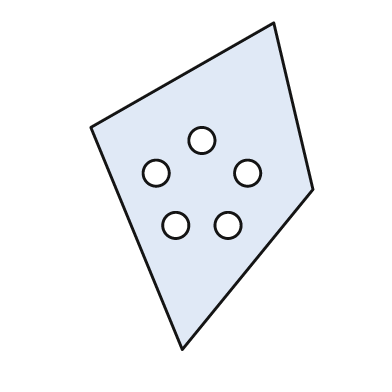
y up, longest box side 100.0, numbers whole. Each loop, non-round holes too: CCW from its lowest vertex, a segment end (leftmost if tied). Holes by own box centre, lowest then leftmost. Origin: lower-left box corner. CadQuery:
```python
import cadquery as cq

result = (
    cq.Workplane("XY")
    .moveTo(28.0, 0.0)
    .lineTo(68.0, 49.0)
    .lineTo(56.0, 100.0)
    .lineTo(0.0, 68.0)
    .close()
    .moveTo(26.0, 38.0)
    .circle(4.0)
    .moveTo(42.0, 38.0)
    .circle(4.0)
    .moveTo(20.0, 54.0)
    .circle(4.0)
    .moveTo(48.0, 54.0)
    .circle(4.0)
    .moveTo(34.0, 64.0)
    .circle(4.0)
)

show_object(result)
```